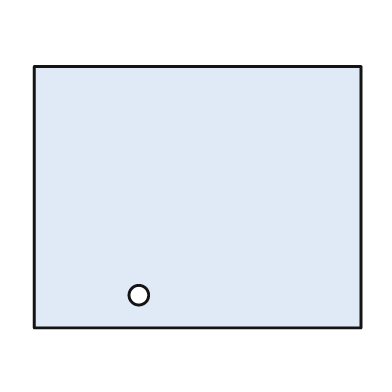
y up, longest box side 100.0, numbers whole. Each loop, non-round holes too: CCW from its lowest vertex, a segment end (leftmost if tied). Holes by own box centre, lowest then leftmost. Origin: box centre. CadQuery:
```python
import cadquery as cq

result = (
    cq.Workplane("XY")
    .moveTo(-50.0, -40.0)
    .lineTo(50.0, -40.0)
    .lineTo(50.0, 40.0)
    .lineTo(-50.0, 40.0)
    .close()
    .moveTo(-18.0, -30.0)
    .circle(3.0)
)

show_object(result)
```